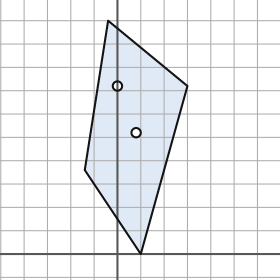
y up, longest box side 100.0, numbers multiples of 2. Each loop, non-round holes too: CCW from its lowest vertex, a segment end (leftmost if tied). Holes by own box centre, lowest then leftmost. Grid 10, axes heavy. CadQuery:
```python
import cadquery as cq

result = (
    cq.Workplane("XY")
    .moveTo(10.0, 0.0)
    .lineTo(30.0, 72.0)
    .lineTo(-4.0, 100.0)
    .lineTo(-14.0, 36.0)
    .close()
    .moveTo(8.0, 52.0)
    .circle(2.0)
    .moveTo(0.0, 72.0)
    .circle(2.0)
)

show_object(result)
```